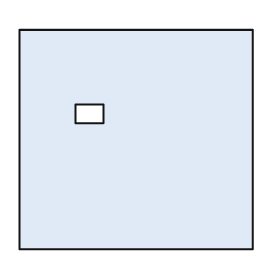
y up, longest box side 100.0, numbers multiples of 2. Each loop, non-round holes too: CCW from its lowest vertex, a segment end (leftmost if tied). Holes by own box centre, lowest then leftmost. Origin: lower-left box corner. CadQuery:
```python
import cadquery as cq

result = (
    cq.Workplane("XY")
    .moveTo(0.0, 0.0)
    .lineTo(100.0, 0.0)
    .lineTo(100.0, 94.0)
    .lineTo(0.0, 94.0)
    .close()
    .moveTo(24.0, 54.0)
    .lineTo(36.0, 54.0)
    .lineTo(36.0, 62.0)
    .lineTo(24.0, 62.0)
    .close()
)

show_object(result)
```